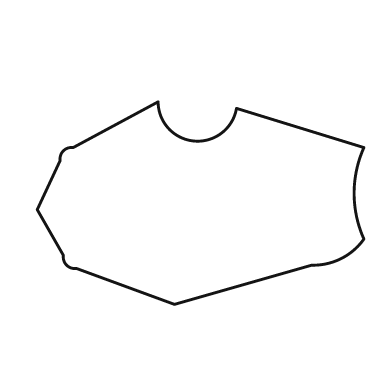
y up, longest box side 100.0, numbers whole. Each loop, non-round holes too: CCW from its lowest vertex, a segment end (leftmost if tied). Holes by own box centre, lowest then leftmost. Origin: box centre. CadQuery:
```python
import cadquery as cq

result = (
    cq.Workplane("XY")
    .moveTo(-8.0, -31.0)
    .lineTo(34.0, -19.0)
    .threePointArc((43.0, -17.0), (50.0, -11.0))
    .threePointArc((47.0, 3.0), (50.0, 17.0))
    .lineTo(11.0, 29.0)
    .threePointArc((-2.0, 19.0), (-13.0, 31.0))
    .lineTo(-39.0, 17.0)
    .threePointArc((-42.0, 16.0), (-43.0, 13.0))
    .lineTo(-50.0, -2.0)
    .lineTo(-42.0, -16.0)
    .threePointArc((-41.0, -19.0), (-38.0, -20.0))
    .close()
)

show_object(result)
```